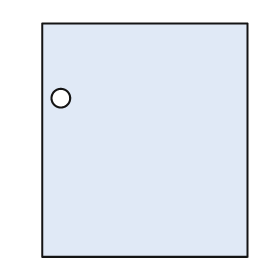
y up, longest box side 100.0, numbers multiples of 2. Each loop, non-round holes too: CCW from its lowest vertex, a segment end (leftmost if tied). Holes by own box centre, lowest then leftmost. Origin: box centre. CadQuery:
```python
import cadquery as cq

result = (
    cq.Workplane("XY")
    .moveTo(-44.0, -50.0)
    .lineTo(44.0, -50.0)
    .lineTo(44.0, 50.0)
    .lineTo(-44.0, 50.0)
    .close()
    .moveTo(-36.0, 18.0)
    .circle(4.0)
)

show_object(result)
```